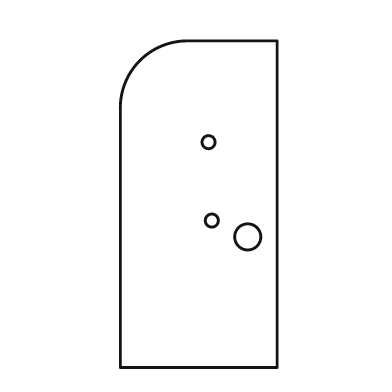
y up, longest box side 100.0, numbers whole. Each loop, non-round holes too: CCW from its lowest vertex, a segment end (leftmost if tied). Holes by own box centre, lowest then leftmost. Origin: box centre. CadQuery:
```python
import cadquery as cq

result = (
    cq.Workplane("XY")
    .moveTo(-24.0, -50.0)
    .lineTo(24.0, -50.0)
    .lineTo(24.0, 50.0)
    .lineTo(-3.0, 50.0)
    .threePointArc((-18.0, 44.0), (-24.0, 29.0))
    .close()
    .moveTo(15.0, -10.0)
    .circle(4.0)
    .moveTo(4.0, -5.0)
    .circle(2.0)
    .moveTo(3.0, 19.0)
    .circle(2.0)
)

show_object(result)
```